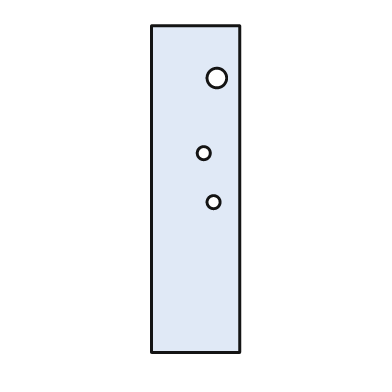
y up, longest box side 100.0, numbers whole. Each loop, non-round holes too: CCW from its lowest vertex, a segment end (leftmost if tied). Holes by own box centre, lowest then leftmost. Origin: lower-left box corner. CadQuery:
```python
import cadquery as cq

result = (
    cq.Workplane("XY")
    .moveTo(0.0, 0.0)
    .lineTo(27.0, 0.0)
    .lineTo(27.0, 100.0)
    .lineTo(0.0, 100.0)
    .close()
    .moveTo(19.0, 46.0)
    .circle(2.0)
    .moveTo(16.0, 61.0)
    .circle(2.0)
    .moveTo(20.0, 84.0)
    .circle(3.0)
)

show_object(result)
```